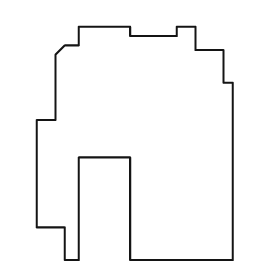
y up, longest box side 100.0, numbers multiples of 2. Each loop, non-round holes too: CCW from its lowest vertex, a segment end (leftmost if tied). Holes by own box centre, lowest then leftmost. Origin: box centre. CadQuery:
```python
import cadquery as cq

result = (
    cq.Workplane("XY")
    .moveTo(-30.0, -50.0)
    .lineTo(-24.0, -50.0)
    .lineTo(-24.0, -6.0)
    .lineTo(-2.0, -6.0)
    .lineTo(-2.0, -50.0)
    .lineTo(42.0, -50.0)
    .lineTo(42.0, 26.0)
    .lineTo(38.0, 26.0)
    .lineTo(38.0, 40.0)
    .lineTo(26.0, 40.0)
    .lineTo(26.0, 50.0)
    .lineTo(18.0, 50.0)
    .lineTo(18.0, 46.0)
    .lineTo(-2.0, 46.0)
    .lineTo(-2.0, 50.0)
    .lineTo(-24.0, 50.0)
    .lineTo(-24.0, 42.0)
    .lineTo(-30.0, 42.0)
    .lineTo(-34.0, 38.0)
    .lineTo(-34.0, 10.0)
    .lineTo(-42.0, 10.0)
    .lineTo(-42.0, -36.0)
    .lineTo(-30.0, -36.0)
    .close()
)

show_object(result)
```